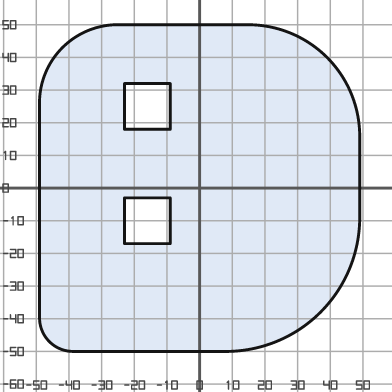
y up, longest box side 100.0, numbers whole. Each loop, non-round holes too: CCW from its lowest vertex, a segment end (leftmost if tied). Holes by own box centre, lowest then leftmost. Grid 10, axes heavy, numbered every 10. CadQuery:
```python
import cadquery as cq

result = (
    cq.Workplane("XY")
    .moveTo(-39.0, -50.0)
    .lineTo(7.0, -50.0)
    .threePointArc((37.0, -38.0), (49.0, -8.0))
    .lineTo(49.0, 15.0)
    .threePointArc((39.0, 40.0), (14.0, 50.0))
    .lineTo(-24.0, 50.0)
    .threePointArc((-42.0, 43.0), (-49.0, 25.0))
    .lineTo(-49.0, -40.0)
    .threePointArc((-46.0, -47.0), (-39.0, -50.0))
    .close()
    .moveTo(-23.0, -17.0)
    .lineTo(-9.0, -17.0)
    .lineTo(-9.0, -3.0)
    .lineTo(-23.0, -3.0)
    .close()
    .moveTo(-23.0, 18.0)
    .lineTo(-9.0, 18.0)
    .lineTo(-9.0, 32.0)
    .lineTo(-23.0, 32.0)
    .close()
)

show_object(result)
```